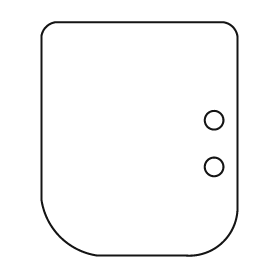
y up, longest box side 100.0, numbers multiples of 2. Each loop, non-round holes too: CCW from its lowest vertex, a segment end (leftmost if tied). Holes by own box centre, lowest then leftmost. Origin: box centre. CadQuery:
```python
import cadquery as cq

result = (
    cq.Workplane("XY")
    .moveTo(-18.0, -50.0)
    .lineTo(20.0, -50.0)
    .threePointArc((36.0, -44.0), (42.0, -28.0))
    .lineTo(42.0, 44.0)
    .threePointArc((40.0, 48.0), (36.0, 50.0))
    .lineTo(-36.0, 50.0)
    .threePointArc((-40.0, 48.0), (-42.0, 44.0))
    .lineTo(-42.0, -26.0)
    .threePointArc((-34.0, -42.0), (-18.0, -50.0))
    .close()
    .moveTo(32.0, -12.0)
    .circle(4.0)
    .moveTo(32.0, 8.0)
    .circle(4.0)
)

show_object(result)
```